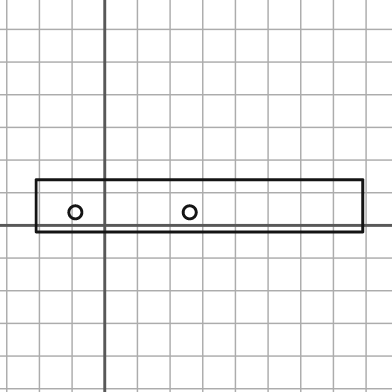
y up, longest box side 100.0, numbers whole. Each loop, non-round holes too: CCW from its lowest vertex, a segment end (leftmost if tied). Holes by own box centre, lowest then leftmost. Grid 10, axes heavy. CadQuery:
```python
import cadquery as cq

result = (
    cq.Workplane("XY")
    .moveTo(-21.0, -2.0)
    .lineTo(79.0, -2.0)
    .lineTo(79.0, 14.0)
    .lineTo(-21.0, 14.0)
    .close()
    .moveTo(-9.0, 4.0)
    .circle(2.0)
    .moveTo(26.0, 4.0)
    .circle(2.0)
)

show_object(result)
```